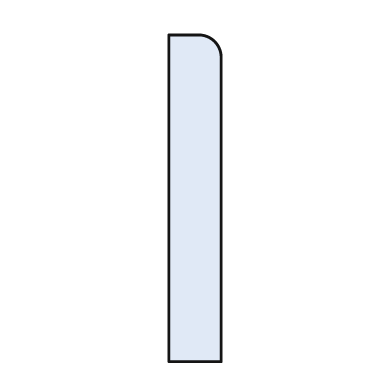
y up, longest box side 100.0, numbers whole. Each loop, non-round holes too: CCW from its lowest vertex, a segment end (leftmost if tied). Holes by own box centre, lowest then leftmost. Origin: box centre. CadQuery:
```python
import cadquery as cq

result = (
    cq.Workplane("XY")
    .moveTo(-8.0, -50.0)
    .lineTo(8.0, -50.0)
    .lineTo(8.0, 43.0)
    .threePointArc((6.0, 48.0), (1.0, 50.0))
    .lineTo(-8.0, 50.0)
    .close()
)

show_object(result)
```